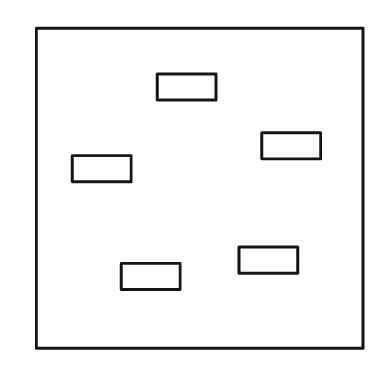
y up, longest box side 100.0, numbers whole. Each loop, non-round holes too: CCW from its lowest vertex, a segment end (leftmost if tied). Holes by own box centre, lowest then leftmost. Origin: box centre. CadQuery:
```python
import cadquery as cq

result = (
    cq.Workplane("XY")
    .moveTo(-50.0, -49.0)
    .lineTo(50.0, -49.0)
    .lineTo(50.0, 49.0)
    .lineTo(-50.0, 49.0)
    .close()
    .moveTo(-24.0, -31.0)
    .lineTo(-6.0, -31.0)
    .lineTo(-6.0, -23.0)
    .lineTo(-24.0, -23.0)
    .close()
    .moveTo(12.0, -26.0)
    .lineTo(30.0, -26.0)
    .lineTo(30.0, -18.0)
    .lineTo(12.0, -18.0)
    .close()
    .moveTo(-39.0, 2.0)
    .lineTo(-21.0, 2.0)
    .lineTo(-21.0, 10.0)
    .lineTo(-39.0, 10.0)
    .close()
    .moveTo(19.0, 9.0)
    .lineTo(37.0, 9.0)
    .lineTo(37.0, 17.0)
    .lineTo(19.0, 17.0)
    .close()
    .moveTo(-13.0, 27.0)
    .lineTo(5.0, 27.0)
    .lineTo(5.0, 35.0)
    .lineTo(-13.0, 35.0)
    .close()
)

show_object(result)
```